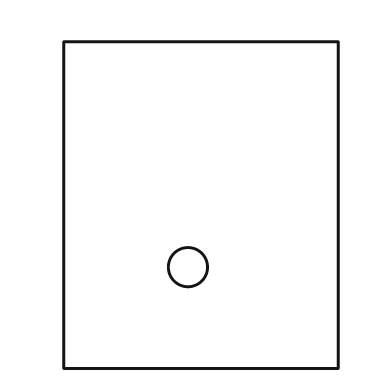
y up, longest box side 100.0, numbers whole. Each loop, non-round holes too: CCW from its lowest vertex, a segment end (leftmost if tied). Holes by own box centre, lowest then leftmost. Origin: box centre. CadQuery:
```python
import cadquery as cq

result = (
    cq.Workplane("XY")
    .moveTo(-42.0, -50.0)
    .lineTo(42.0, -50.0)
    .lineTo(42.0, 50.0)
    .lineTo(-42.0, 50.0)
    .close()
    .moveTo(-4.0, -19.0)
    .circle(6.0)
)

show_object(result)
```